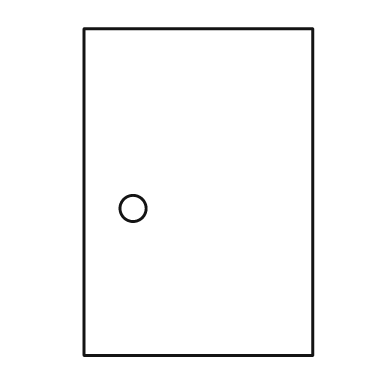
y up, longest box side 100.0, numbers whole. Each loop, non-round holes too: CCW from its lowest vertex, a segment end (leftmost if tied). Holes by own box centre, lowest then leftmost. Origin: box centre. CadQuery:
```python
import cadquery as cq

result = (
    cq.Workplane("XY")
    .moveTo(-35.0, -50.0)
    .lineTo(35.0, -50.0)
    .lineTo(35.0, 50.0)
    .lineTo(-35.0, 50.0)
    .close()
    .moveTo(-20.0, -5.0)
    .circle(4.0)
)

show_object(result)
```